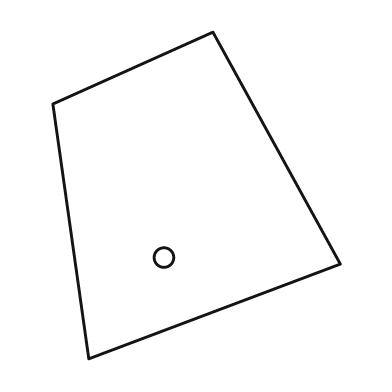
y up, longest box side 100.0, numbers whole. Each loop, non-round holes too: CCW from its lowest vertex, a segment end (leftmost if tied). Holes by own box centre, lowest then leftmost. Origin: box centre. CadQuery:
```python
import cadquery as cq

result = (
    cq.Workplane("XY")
    .moveTo(-33.0, -50.0)
    .lineTo(44.0, -21.0)
    .lineTo(5.0, 50.0)
    .lineTo(-44.0, 28.0)
    .close()
    .moveTo(-10.0, -19.0)
    .circle(3.0)
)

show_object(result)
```